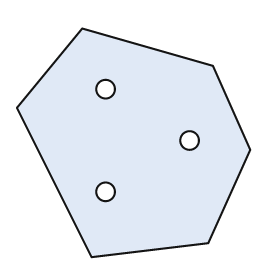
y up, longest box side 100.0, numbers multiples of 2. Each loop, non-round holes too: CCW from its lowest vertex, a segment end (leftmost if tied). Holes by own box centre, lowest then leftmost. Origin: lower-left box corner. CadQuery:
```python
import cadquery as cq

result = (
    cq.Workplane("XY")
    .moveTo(32.0, 0.0)
    .lineTo(82.0, 6.0)
    .lineTo(100.0, 46.0)
    .lineTo(84.0, 82.0)
    .lineTo(28.0, 98.0)
    .lineTo(0.0, 64.0)
    .close()
    .moveTo(38.0, 28.0)
    .circle(4.0)
    .moveTo(74.0, 50.0)
    .circle(4.0)
    .moveTo(38.0, 72.0)
    .circle(4.0)
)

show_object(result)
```